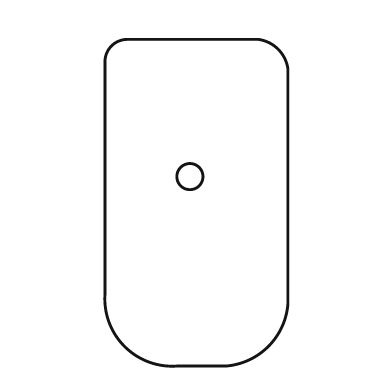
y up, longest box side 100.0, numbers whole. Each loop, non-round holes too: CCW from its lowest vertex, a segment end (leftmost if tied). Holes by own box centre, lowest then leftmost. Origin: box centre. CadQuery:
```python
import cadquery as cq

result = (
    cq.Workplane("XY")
    .moveTo(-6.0, -50.0)
    .lineTo(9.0, -50.0)
    .threePointArc((22.0, -44.0), (28.0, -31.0))
    .lineTo(28.0, 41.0)
    .threePointArc((25.0, 47.0), (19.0, 50.0))
    .lineTo(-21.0, 50.0)
    .threePointArc((-26.0, 48.0), (-28.0, 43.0))
    .lineTo(-28.0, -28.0)
    .threePointArc((-22.0, -44.0), (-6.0, -50.0))
    .close()
    .moveTo(-2.0, 8.0)
    .circle(4.0)
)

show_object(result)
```